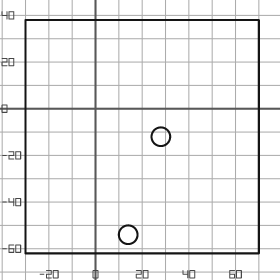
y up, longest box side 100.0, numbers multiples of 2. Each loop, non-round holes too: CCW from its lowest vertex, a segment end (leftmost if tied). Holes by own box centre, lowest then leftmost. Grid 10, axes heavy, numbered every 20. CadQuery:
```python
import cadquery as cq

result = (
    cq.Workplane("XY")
    .moveTo(-30.0, -62.0)
    .lineTo(70.0, -62.0)
    .lineTo(70.0, 38.0)
    .lineTo(-30.0, 38.0)
    .close()
    .moveTo(14.0, -54.0)
    .circle(4.0)
    .moveTo(28.0, -12.0)
    .circle(4.0)
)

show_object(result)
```